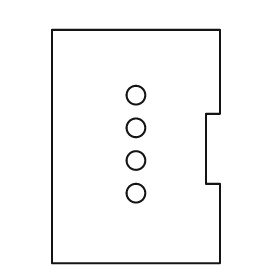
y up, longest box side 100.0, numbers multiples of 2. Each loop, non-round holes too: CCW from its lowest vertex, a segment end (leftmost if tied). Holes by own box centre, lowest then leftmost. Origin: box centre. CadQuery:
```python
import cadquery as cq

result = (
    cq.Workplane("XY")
    .moveTo(-36.0, -50.0)
    .lineTo(36.0, -50.0)
    .lineTo(36.0, -16.0)
    .lineTo(30.0, -16.0)
    .lineTo(30.0, 14.0)
    .lineTo(36.0, 14.0)
    .lineTo(36.0, 50.0)
    .lineTo(-36.0, 50.0)
    .close()
    .moveTo(0.0, -20.0)
    .circle(4.0)
    .moveTo(0.0, -6.0)
    .circle(4.0)
    .moveTo(0.0, 8.0)
    .circle(4.0)
    .moveTo(0.0, 22.0)
    .circle(4.0)
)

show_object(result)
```